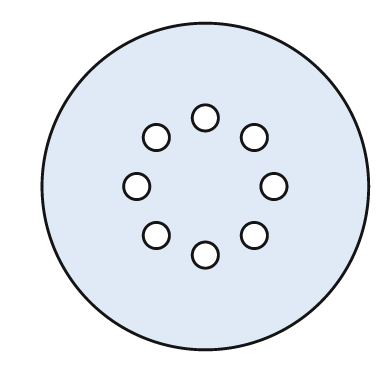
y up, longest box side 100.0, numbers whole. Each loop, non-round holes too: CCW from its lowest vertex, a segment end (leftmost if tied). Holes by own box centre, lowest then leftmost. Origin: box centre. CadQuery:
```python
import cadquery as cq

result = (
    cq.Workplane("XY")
    .moveTo(0.0, 0.0)
    .circle(50.0)
    .moveTo(0.0, -21.0)
    .circle(4.0)
    .moveTo(-15.0, -15.0)
    .circle(4.0)
    .moveTo(15.0, -15.0)
    .circle(4.0)
    .moveTo(-21.0, 0.0)
    .circle(4.0)
    .moveTo(21.0, 0.0)
    .circle(4.0)
    .moveTo(-15.0, 15.0)
    .circle(4.0)
    .moveTo(15.0, 15.0)
    .circle(4.0)
    .moveTo(0.0, 21.0)
    .circle(4.0)
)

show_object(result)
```